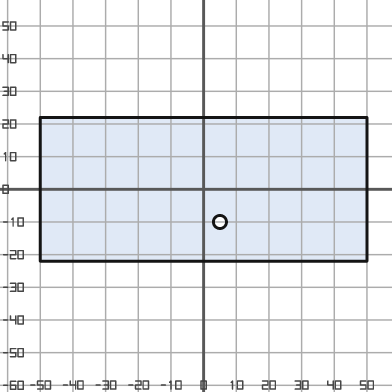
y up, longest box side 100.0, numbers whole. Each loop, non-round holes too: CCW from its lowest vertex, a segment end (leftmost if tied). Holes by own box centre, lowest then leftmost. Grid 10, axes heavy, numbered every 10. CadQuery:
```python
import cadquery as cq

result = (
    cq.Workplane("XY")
    .moveTo(-50.0, -22.0)
    .lineTo(50.0, -22.0)
    .lineTo(50.0, 22.0)
    .lineTo(-50.0, 22.0)
    .close()
    .moveTo(5.0, -10.0)
    .circle(2.0)
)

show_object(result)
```